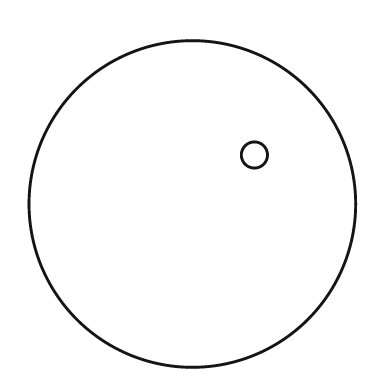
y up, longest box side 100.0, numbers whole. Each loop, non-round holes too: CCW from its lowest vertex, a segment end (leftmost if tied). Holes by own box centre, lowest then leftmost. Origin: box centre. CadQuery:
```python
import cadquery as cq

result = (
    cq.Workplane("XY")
    .moveTo(0.0, 0.0)
    .circle(50.0)
    .moveTo(19.0, 15.0)
    .circle(4.0)
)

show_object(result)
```